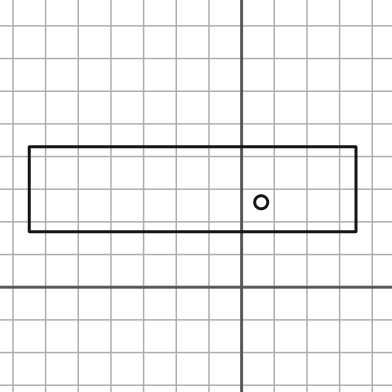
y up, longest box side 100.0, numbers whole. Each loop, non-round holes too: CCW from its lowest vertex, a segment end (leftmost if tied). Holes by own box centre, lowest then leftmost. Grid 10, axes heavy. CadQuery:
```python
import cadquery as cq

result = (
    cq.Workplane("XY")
    .moveTo(-65.0, 17.0)
    .lineTo(35.0, 17.0)
    .lineTo(35.0, 43.0)
    .lineTo(-65.0, 43.0)
    .close()
    .moveTo(6.0, 26.0)
    .circle(2.0)
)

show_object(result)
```